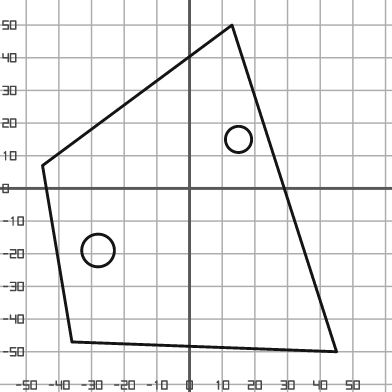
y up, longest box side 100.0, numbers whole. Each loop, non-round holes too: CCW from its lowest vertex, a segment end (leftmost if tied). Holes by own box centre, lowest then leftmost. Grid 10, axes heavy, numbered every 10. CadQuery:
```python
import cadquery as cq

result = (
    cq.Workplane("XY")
    .moveTo(45.0, -50.0)
    .lineTo(13.0, 50.0)
    .lineTo(-45.0, 7.0)
    .lineTo(-36.0, -47.0)
    .close()
    .moveTo(-28.0, -19.0)
    .circle(5.0)
    .moveTo(15.0, 15.0)
    .circle(4.0)
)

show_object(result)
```